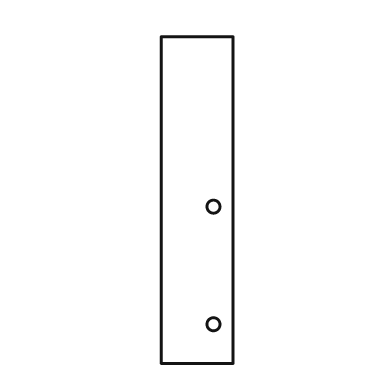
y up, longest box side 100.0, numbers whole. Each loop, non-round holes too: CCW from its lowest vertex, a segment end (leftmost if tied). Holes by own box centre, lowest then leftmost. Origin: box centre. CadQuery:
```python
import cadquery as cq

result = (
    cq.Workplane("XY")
    .moveTo(-11.0, -50.0)
    .lineTo(11.0, -50.0)
    .lineTo(11.0, 50.0)
    .lineTo(-11.0, 50.0)
    .close()
    .moveTo(5.0, -38.0)
    .circle(2.0)
    .moveTo(5.0, -2.0)
    .circle(2.0)
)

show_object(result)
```